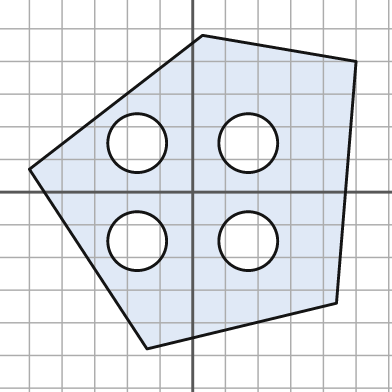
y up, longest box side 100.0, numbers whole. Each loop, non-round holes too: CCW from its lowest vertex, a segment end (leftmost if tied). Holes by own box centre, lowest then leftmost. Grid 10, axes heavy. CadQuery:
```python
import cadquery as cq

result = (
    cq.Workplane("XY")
    .moveTo(-14.0, -48.0)
    .lineTo(44.0, -34.0)
    .lineTo(50.0, 40.0)
    .lineTo(3.0, 48.0)
    .lineTo(-50.0, 7.0)
    .close()
    .moveTo(-17.0, -15.0)
    .circle(9.0)
    .moveTo(17.0, -15.0)
    .circle(9.0)
    .moveTo(-17.0, 15.0)
    .circle(9.0)
    .moveTo(17.0, 15.0)
    .circle(9.0)
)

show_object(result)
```